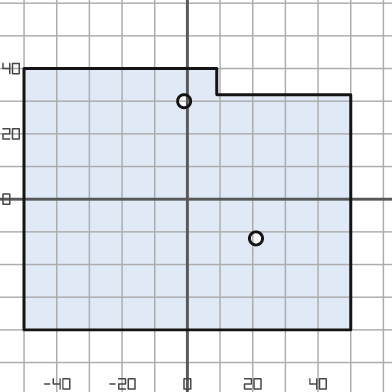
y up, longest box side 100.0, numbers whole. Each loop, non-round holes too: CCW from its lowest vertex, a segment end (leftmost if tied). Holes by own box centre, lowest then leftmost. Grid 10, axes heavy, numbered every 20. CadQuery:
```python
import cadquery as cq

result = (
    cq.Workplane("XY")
    .moveTo(-50.0, -40.0)
    .lineTo(50.0, -40.0)
    .lineTo(50.0, 32.0)
    .lineTo(9.0, 32.0)
    .lineTo(9.0, 40.0)
    .lineTo(-50.0, 40.0)
    .close()
    .moveTo(21.0, -12.0)
    .circle(2.0)
    .moveTo(-1.0, 30.0)
    .circle(2.0)
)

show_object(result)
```